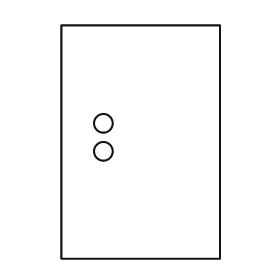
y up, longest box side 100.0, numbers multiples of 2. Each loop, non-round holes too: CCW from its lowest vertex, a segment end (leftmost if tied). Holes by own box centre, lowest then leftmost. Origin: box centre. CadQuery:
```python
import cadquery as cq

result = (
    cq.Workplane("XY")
    .moveTo(-34.0, -50.0)
    .lineTo(34.0, -50.0)
    .lineTo(34.0, 50.0)
    .lineTo(-34.0, 50.0)
    .close()
    .moveTo(-16.0, -4.0)
    .circle(4.0)
    .moveTo(-16.0, 8.0)
    .circle(4.0)
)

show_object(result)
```